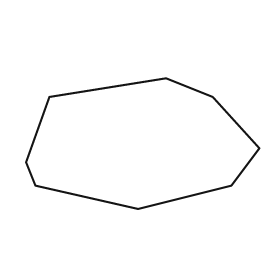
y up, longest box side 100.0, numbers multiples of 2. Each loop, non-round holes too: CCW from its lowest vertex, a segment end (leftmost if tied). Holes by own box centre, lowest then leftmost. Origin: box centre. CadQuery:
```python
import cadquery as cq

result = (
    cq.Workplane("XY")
    .moveTo(-2.0, -28.0)
    .lineTo(38.0, -18.0)
    .lineTo(50.0, -2.0)
    .lineTo(30.0, 20.0)
    .lineTo(10.0, 28.0)
    .lineTo(-40.0, 20.0)
    .lineTo(-50.0, -8.0)
    .lineTo(-46.0, -18.0)
    .close()
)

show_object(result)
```